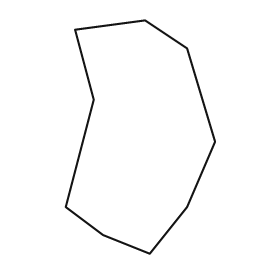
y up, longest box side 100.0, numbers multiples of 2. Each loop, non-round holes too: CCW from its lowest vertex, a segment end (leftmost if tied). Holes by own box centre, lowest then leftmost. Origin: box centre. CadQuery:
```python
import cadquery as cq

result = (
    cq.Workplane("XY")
    .moveTo(4.0, -50.0)
    .lineTo(20.0, -30.0)
    .lineTo(32.0, -2.0)
    .lineTo(20.0, 38.0)
    .lineTo(2.0, 50.0)
    .lineTo(-28.0, 46.0)
    .lineTo(-20.0, 16.0)
    .lineTo(-32.0, -30.0)
    .lineTo(-16.0, -42.0)
    .close()
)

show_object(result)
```